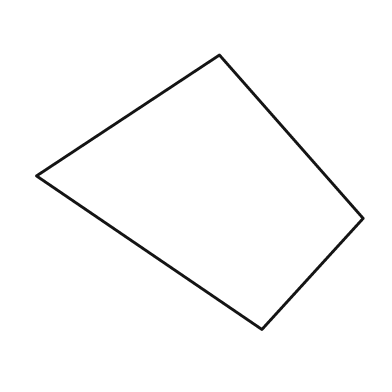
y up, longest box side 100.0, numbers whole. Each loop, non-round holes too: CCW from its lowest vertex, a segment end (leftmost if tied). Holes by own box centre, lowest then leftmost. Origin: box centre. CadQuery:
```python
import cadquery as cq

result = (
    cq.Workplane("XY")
    .moveTo(19.0, -42.0)
    .lineTo(50.0, -8.0)
    .lineTo(6.0, 42.0)
    .lineTo(-50.0, 5.0)
    .close()
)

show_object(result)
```